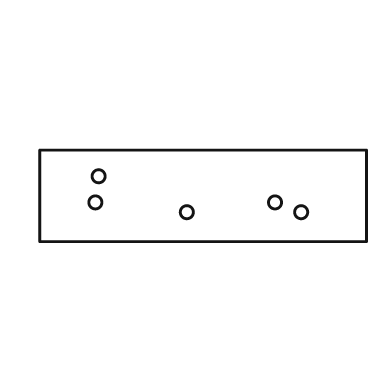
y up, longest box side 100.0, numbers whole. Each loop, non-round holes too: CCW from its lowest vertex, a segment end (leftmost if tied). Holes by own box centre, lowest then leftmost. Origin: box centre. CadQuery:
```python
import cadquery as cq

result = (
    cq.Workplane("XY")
    .moveTo(-50.0, -14.0)
    .lineTo(50.0, -14.0)
    .lineTo(50.0, 14.0)
    .lineTo(-50.0, 14.0)
    .close()
    .moveTo(-5.0, -5.0)
    .circle(2.0)
    .moveTo(30.0, -5.0)
    .circle(2.0)
    .moveTo(-33.0, -2.0)
    .circle(2.0)
    .moveTo(22.0, -2.0)
    .circle(2.0)
    .moveTo(-32.0, 6.0)
    .circle(2.0)
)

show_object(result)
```